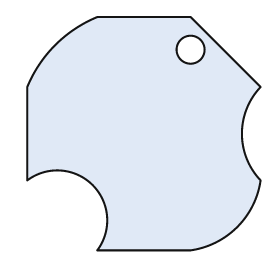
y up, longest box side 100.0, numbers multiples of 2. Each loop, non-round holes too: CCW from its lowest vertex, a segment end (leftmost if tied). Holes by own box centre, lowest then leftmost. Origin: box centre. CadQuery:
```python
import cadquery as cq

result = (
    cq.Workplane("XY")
    .moveTo(-20.0, -50.0)
    .lineTo(20.0, -50.0)
    .threePointArc((40.0, -40.0), (50.0, -20.0))
    .threePointArc((42.0, 0.0), (50.0, 20.0))
    .lineTo(20.0, 50.0)
    .lineTo(-20.0, 50.0)
    .threePointArc((-38.0, 38.0), (-50.0, 20.0))
    .lineTo(-50.0, -20.0)
    .threePointArc((-22.0, -22.0), (-20.0, -50.0))
    .close()
    .moveTo(20.0, 36.0)
    .circle(6.0)
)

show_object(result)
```